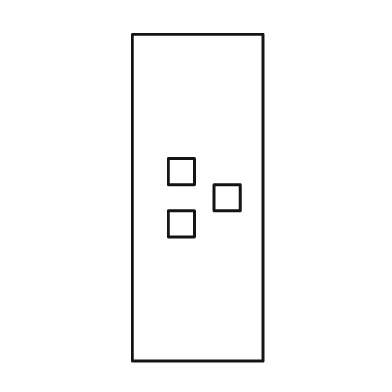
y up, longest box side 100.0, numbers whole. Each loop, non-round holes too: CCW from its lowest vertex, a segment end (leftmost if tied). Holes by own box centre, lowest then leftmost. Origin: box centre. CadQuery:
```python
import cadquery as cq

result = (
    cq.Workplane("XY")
    .moveTo(-20.0, -50.0)
    .lineTo(20.0, -50.0)
    .lineTo(20.0, 50.0)
    .lineTo(-20.0, 50.0)
    .close()
    .moveTo(-9.0, -12.0)
    .lineTo(-1.0, -12.0)
    .lineTo(-1.0, -4.0)
    .lineTo(-9.0, -4.0)
    .close()
    .moveTo(5.0, -4.0)
    .lineTo(13.0, -4.0)
    .lineTo(13.0, 4.0)
    .lineTo(5.0, 4.0)
    .close()
    .moveTo(-9.0, 4.0)
    .lineTo(-1.0, 4.0)
    .lineTo(-1.0, 12.0)
    .lineTo(-9.0, 12.0)
    .close()
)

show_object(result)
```